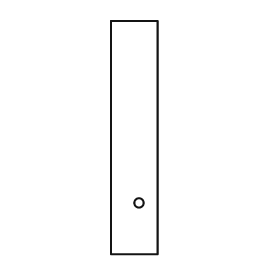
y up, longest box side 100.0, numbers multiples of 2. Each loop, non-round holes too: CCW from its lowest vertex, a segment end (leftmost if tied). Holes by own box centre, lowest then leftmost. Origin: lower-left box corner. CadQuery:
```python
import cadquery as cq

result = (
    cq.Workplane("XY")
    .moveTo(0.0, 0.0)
    .lineTo(20.0, 0.0)
    .lineTo(20.0, 100.0)
    .lineTo(0.0, 100.0)
    .close()
    .moveTo(12.0, 22.0)
    .circle(2.0)
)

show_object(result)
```